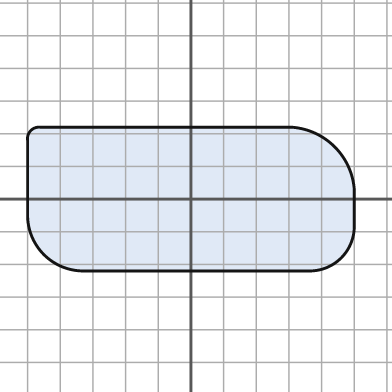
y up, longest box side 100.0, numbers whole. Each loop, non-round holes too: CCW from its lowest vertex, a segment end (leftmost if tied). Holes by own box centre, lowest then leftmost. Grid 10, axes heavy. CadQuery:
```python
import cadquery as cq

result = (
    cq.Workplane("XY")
    .moveTo(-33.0, -22.0)
    .lineTo(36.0, -22.0)
    .threePointArc((46.0, -18.0), (50.0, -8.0))
    .lineTo(50.0, 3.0)
    .threePointArc((44.0, 16.0), (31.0, 22.0))
    .lineTo(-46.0, 22.0)
    .threePointArc((-49.0, 21.0), (-50.0, 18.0))
    .lineTo(-50.0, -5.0)
    .threePointArc((-45.0, -17.0), (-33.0, -22.0))
    .close()
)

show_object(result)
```